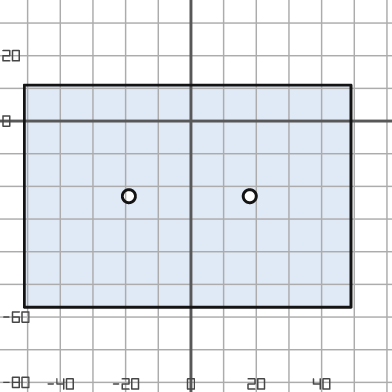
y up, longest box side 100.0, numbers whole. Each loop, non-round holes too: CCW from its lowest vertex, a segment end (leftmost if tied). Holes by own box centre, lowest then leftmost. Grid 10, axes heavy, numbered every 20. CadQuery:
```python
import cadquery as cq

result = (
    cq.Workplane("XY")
    .moveTo(-51.0, -57.0)
    .lineTo(49.0, -57.0)
    .lineTo(49.0, 11.0)
    .lineTo(-51.0, 11.0)
    .close()
    .moveTo(-19.0, -23.0)
    .circle(2.0)
    .moveTo(18.0, -23.0)
    .circle(2.0)
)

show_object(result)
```